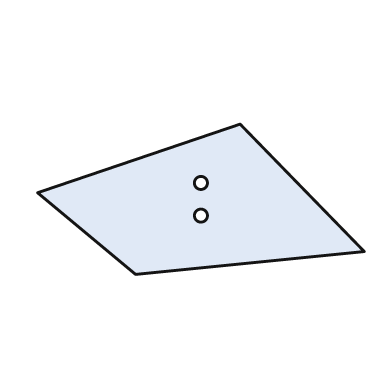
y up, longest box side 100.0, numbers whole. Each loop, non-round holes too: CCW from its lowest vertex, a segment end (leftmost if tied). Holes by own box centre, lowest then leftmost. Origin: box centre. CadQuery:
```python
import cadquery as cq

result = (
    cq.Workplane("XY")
    .moveTo(-20.0, -23.0)
    .lineTo(50.0, -16.0)
    .lineTo(12.0, 23.0)
    .lineTo(-50.0, 2.0)
    .close()
    .moveTo(0.0, -5.0)
    .circle(2.0)
    .moveTo(0.0, 5.0)
    .circle(2.0)
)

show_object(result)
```